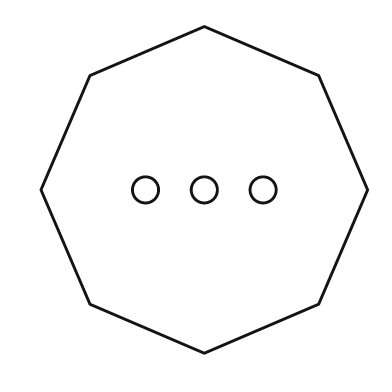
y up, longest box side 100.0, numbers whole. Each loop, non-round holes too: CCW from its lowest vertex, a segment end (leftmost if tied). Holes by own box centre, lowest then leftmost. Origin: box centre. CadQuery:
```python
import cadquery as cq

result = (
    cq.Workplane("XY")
    .moveTo(0.0, -50.0)
    .lineTo(35.0, -35.0)
    .lineTo(50.0, 0.0)
    .lineTo(35.0, 35.0)
    .lineTo(0.0, 50.0)
    .lineTo(-35.0, 35.0)
    .lineTo(-50.0, 0.0)
    .lineTo(-35.0, -35.0)
    .close()
    .moveTo(-18.0, 0.0)
    .circle(4.0)
    .moveTo(0.0, 0.0)
    .circle(4.0)
    .moveTo(18.0, 0.0)
    .circle(4.0)
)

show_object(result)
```